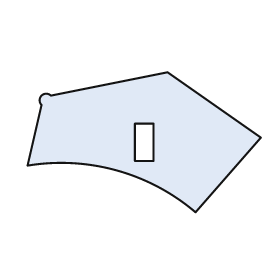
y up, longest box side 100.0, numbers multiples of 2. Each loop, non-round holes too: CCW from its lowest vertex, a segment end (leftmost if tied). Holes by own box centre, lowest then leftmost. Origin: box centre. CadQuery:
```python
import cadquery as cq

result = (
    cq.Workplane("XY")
    .moveTo(22.0, -30.0)
    .lineTo(50.0, 2.0)
    .lineTo(10.0, 30.0)
    .lineTo(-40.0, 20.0)
    .threePointArc((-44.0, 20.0), (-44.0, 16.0))
    .lineTo(-50.0, -10.0)
    .threePointArc((-12.0, -12.0), (22.0, -30.0))
    .close()
    .moveTo(-4.0, -8.0)
    .lineTo(4.0, -8.0)
    .lineTo(4.0, 8.0)
    .lineTo(-4.0, 8.0)
    .close()
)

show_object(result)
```